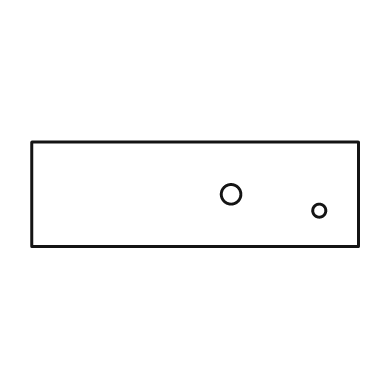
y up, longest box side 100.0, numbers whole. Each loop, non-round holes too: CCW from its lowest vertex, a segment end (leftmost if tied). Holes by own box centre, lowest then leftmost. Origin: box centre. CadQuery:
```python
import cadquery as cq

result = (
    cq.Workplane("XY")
    .moveTo(-50.0, -16.0)
    .lineTo(50.0, -16.0)
    .lineTo(50.0, 16.0)
    .lineTo(-50.0, 16.0)
    .close()
    .moveTo(38.0, -5.0)
    .circle(2.0)
    .moveTo(11.0, 0.0)
    .circle(3.0)
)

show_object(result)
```